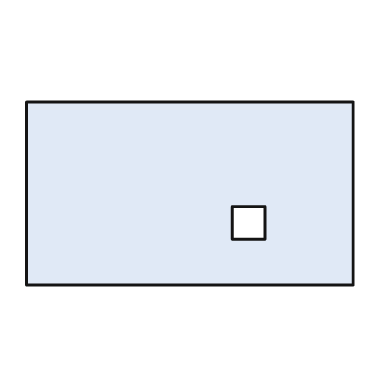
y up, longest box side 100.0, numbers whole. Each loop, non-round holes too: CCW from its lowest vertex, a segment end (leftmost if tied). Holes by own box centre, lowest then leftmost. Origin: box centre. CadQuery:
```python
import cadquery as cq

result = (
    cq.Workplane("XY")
    .moveTo(-50.0, -28.0)
    .lineTo(50.0, -28.0)
    .lineTo(50.0, 28.0)
    .lineTo(-50.0, 28.0)
    .close()
    .moveTo(13.0, -14.0)
    .lineTo(23.0, -14.0)
    .lineTo(23.0, -4.0)
    .lineTo(13.0, -4.0)
    .close()
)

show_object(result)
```